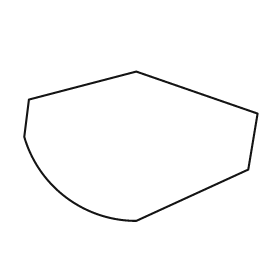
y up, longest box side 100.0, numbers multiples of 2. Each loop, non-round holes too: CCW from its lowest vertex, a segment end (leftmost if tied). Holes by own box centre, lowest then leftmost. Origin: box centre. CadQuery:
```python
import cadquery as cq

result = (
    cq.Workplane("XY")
    .moveTo(-2.0, -32.0)
    .lineTo(46.0, -10.0)
    .lineTo(50.0, 14.0)
    .lineTo(-2.0, 32.0)
    .lineTo(-48.0, 20.0)
    .lineTo(-50.0, 4.0)
    .threePointArc((-32.0, -22.0), (-2.0, -32.0))
    .close()
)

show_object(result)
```